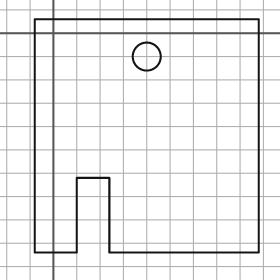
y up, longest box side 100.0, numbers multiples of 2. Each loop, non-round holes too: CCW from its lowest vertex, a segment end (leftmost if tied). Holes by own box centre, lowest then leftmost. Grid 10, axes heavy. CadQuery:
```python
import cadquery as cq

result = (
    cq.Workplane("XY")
    .moveTo(-8.0, -94.0)
    .lineTo(10.0, -94.0)
    .lineTo(10.0, -62.0)
    .lineTo(24.0, -62.0)
    .lineTo(24.0, -94.0)
    .lineTo(88.0, -94.0)
    .lineTo(88.0, 6.0)
    .lineTo(-8.0, 6.0)
    .close()
    .moveTo(40.0, -10.0)
    .circle(6.0)
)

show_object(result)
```